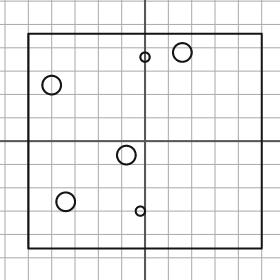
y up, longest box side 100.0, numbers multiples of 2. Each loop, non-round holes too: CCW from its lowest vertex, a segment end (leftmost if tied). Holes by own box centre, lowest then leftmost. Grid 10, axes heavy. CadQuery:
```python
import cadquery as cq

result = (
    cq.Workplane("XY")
    .moveTo(-50.0, -46.0)
    .lineTo(50.0, -46.0)
    .lineTo(50.0, 46.0)
    .lineTo(-50.0, 46.0)
    .close()
    .moveTo(-2.0, -30.0)
    .circle(2.0)
    .moveTo(-34.0, -26.0)
    .circle(4.0)
    .moveTo(-8.0, -6.0)
    .circle(4.0)
    .moveTo(-40.0, 24.0)
    .circle(4.0)
    .moveTo(0.0, 36.0)
    .circle(2.0)
    .moveTo(16.0, 38.0)
    .circle(4.0)
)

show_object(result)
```